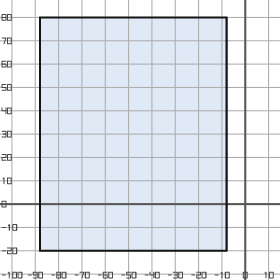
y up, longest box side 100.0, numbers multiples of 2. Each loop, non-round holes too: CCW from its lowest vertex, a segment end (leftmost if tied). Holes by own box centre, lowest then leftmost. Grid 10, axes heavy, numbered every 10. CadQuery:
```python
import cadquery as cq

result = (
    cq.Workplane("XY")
    .moveTo(-88.0, -20.0)
    .lineTo(-8.0, -20.0)
    .lineTo(-8.0, 80.0)
    .lineTo(-88.0, 80.0)
    .close()
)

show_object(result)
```